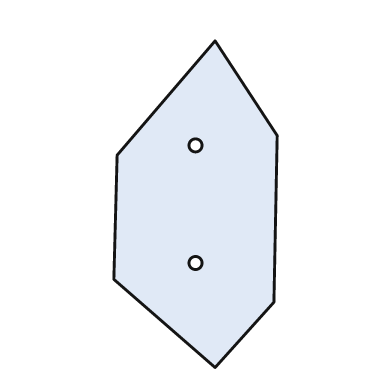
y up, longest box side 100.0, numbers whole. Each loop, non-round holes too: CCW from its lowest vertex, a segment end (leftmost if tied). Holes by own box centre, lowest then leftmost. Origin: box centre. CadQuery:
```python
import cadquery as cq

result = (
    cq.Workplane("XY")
    .moveTo(6.0, -50.0)
    .lineTo(24.0, -30.0)
    .lineTo(25.0, 21.0)
    .lineTo(6.0, 50.0)
    .lineTo(-24.0, 15.0)
    .lineTo(-25.0, -23.0)
    .close()
    .moveTo(0.0, -18.0)
    .circle(2.0)
    .moveTo(0.0, 18.0)
    .circle(2.0)
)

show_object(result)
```